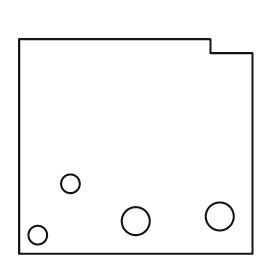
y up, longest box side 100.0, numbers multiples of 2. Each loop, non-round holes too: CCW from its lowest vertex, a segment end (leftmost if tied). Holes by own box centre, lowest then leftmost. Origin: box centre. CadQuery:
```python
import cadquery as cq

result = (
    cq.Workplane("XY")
    .moveTo(-50.0, -46.0)
    .lineTo(50.0, -46.0)
    .lineTo(50.0, 40.0)
    .lineTo(32.0, 40.0)
    .lineTo(32.0, 46.0)
    .lineTo(-50.0, 46.0)
    .close()
    .moveTo(-42.0, -38.0)
    .circle(4.0)
    .moveTo(0.0, -32.0)
    .circle(6.0)
    .moveTo(36.0, -30.0)
    .circle(6.0)
    .moveTo(-28.0, -16.0)
    .circle(4.0)
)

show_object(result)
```